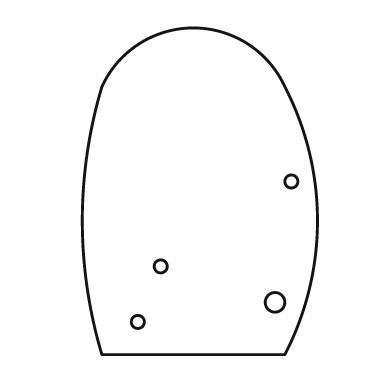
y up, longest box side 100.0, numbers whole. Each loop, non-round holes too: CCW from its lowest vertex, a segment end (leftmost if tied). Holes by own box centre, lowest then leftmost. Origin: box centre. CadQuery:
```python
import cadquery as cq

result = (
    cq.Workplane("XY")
    .moveTo(-30.0, -50.0)
    .lineTo(26.0, -50.0)
    .threePointArc((36.0, -9.0), (26.0, 32.0))
    .threePointArc((-2.0, 50.0), (-30.0, 32.0))
    .threePointArc((-36.0, -9.0), (-30.0, -50.0))
    .close()
    .moveTo(-19.0, -40.0)
    .circle(2.0)
    .moveTo(23.0, -34.0)
    .circle(3.0)
    .moveTo(-12.0, -23.0)
    .circle(2.0)
    .moveTo(28.0, 3.0)
    .circle(2.0)
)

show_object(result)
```